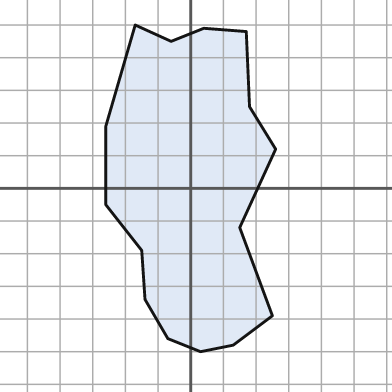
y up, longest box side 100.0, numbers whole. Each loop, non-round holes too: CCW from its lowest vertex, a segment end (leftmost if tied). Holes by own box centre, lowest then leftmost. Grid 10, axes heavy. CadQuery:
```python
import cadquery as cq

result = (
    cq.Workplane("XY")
    .moveTo(3.0, -50.0)
    .lineTo(13.0, -48.0)
    .lineTo(25.0, -39.0)
    .lineTo(15.0, -12.0)
    .lineTo(26.0, 12.0)
    .lineTo(18.0, 25.0)
    .lineTo(17.0, 48.0)
    .lineTo(4.0, 49.0)
    .lineTo(-6.0, 45.0)
    .lineTo(-17.0, 50.0)
    .lineTo(-26.0, 19.0)
    .lineTo(-26.0, -5.0)
    .lineTo(-15.0, -19.0)
    .lineTo(-14.0, -34.0)
    .lineTo(-7.0, -46.0)
    .close()
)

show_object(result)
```